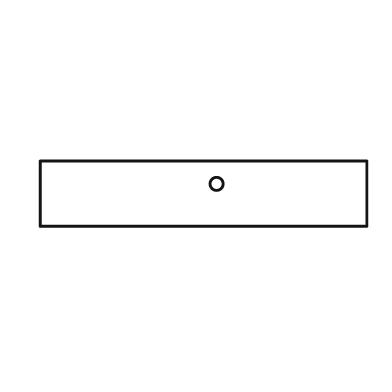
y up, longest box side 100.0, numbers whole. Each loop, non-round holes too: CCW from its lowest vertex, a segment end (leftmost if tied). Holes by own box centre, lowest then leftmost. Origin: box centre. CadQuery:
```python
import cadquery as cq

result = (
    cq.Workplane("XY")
    .moveTo(-50.0, -10.0)
    .lineTo(50.0, -10.0)
    .lineTo(50.0, 10.0)
    .lineTo(-50.0, 10.0)
    .close()
    .moveTo(4.0, 3.0)
    .circle(2.0)
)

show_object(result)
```